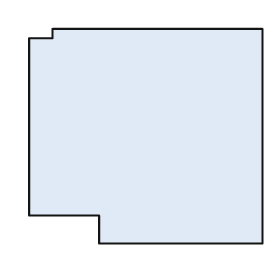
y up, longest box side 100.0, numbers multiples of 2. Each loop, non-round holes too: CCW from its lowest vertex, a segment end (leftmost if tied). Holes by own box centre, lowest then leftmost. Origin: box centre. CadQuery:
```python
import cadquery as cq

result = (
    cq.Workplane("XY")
    .moveTo(-20.0, -46.0)
    .lineTo(50.0, -46.0)
    .lineTo(50.0, 46.0)
    .lineTo(-40.0, 46.0)
    .lineTo(-40.0, 42.0)
    .lineTo(-50.0, 42.0)
    .lineTo(-50.0, -34.0)
    .lineTo(-20.0, -34.0)
    .close()
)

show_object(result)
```